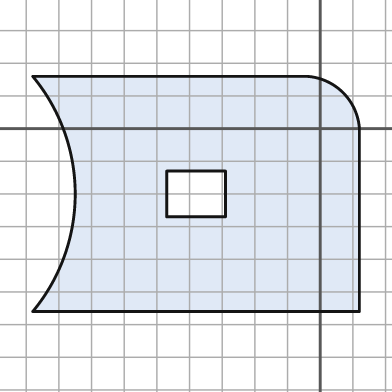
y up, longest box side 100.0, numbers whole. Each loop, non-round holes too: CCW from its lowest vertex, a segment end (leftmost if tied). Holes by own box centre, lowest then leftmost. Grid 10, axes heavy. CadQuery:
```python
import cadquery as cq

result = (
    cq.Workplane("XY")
    .moveTo(-88.0, -56.0)
    .lineTo(12.0, -56.0)
    .lineTo(12.0, 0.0)
    .threePointArc((7.0, 11.0), (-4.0, 16.0))
    .lineTo(-88.0, 16.0)
    .threePointArc((-75.0, -20.0), (-88.0, -56.0))
    .close()
    .moveTo(-47.0, -27.0)
    .lineTo(-29.0, -27.0)
    .lineTo(-29.0, -13.0)
    .lineTo(-47.0, -13.0)
    .close()
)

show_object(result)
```